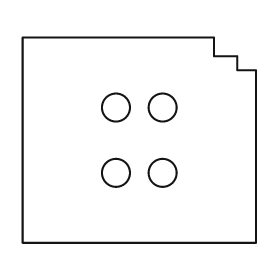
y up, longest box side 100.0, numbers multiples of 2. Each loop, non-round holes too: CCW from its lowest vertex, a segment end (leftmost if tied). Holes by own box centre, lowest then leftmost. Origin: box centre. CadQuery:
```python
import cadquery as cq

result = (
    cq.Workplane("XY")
    .moveTo(-50.0, -44.0)
    .lineTo(50.0, -44.0)
    .lineTo(50.0, 30.0)
    .lineTo(42.0, 30.0)
    .lineTo(42.0, 36.0)
    .lineTo(32.0, 36.0)
    .lineTo(32.0, 44.0)
    .lineTo(-50.0, 44.0)
    .close()
    .moveTo(-10.0, -14.0)
    .circle(6.0)
    .moveTo(10.0, -14.0)
    .circle(6.0)
    .moveTo(-10.0, 14.0)
    .circle(6.0)
    .moveTo(10.0, 14.0)
    .circle(6.0)
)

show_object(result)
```